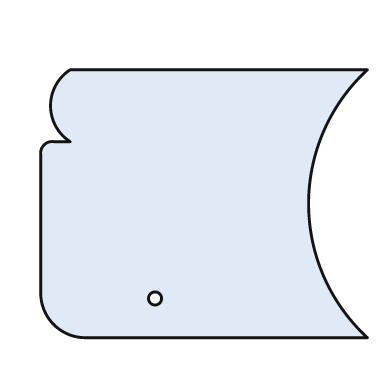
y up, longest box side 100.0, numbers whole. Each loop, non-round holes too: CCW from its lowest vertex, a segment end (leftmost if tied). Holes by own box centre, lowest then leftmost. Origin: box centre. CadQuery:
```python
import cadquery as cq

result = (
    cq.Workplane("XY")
    .moveTo(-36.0, -41.0)
    .lineTo(50.0, -41.0)
    .threePointArc((32.0, 0.0), (50.0, 41.0))
    .lineTo(-41.0, 41.0)
    .threePointArc((-47.0, 30.0), (-41.0, 19.0))
    .lineTo(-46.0, 19.0)
    .threePointArc((-49.0, 18.0), (-50.0, 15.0))
    .lineTo(-50.0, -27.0)
    .threePointArc((-46.0, -37.0), (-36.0, -41.0))
    .close()
    .moveTo(-15.0, -29.0)
    .circle(2.0)
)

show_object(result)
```